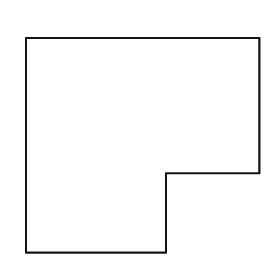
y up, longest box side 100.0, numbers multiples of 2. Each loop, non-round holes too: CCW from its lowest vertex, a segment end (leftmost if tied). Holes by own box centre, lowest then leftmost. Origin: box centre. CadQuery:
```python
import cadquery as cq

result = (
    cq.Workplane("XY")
    .moveTo(-50.0, -46.0)
    .lineTo(10.0, -46.0)
    .lineTo(10.0, -12.0)
    .lineTo(50.0, -12.0)
    .lineTo(50.0, 46.0)
    .lineTo(-50.0, 46.0)
    .close()
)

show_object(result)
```